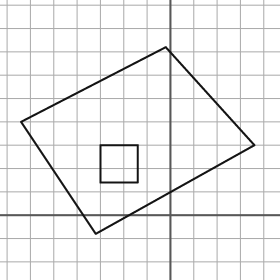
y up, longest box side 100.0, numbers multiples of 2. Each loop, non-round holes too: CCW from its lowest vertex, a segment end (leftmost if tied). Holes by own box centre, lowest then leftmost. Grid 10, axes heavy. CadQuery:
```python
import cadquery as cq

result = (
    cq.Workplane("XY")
    .moveTo(-32.0, -8.0)
    .lineTo(36.0, 30.0)
    .lineTo(-2.0, 72.0)
    .lineTo(-64.0, 40.0)
    .close()
    .moveTo(-30.0, 14.0)
    .lineTo(-14.0, 14.0)
    .lineTo(-14.0, 30.0)
    .lineTo(-30.0, 30.0)
    .close()
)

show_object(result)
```